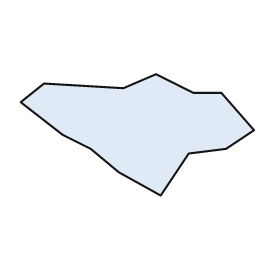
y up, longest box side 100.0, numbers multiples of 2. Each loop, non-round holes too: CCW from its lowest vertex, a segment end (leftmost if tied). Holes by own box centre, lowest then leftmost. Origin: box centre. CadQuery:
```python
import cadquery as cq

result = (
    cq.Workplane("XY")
    .moveTo(10.0, -26.0)
    .lineTo(22.0, -8.0)
    .lineTo(38.0, -6.0)
    .lineTo(50.0, 2.0)
    .lineTo(36.0, 18.0)
    .lineTo(24.0, 18.0)
    .lineTo(8.0, 26.0)
    .lineTo(-6.0, 20.0)
    .lineTo(-40.0, 22.0)
    .lineTo(-50.0, 14.0)
    .lineTo(-32.0, 0.0)
    .lineTo(-20.0, -6.0)
    .lineTo(-8.0, -16.0)
    .close()
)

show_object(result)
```